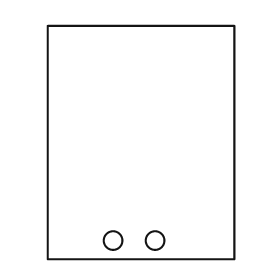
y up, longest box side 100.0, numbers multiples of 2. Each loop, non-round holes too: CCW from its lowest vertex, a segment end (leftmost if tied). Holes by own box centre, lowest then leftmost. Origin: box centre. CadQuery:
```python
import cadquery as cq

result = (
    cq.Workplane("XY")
    .moveTo(-40.0, -50.0)
    .lineTo(40.0, -50.0)
    .lineTo(40.0, 50.0)
    .lineTo(-40.0, 50.0)
    .close()
    .moveTo(-12.0, -42.0)
    .circle(4.0)
    .moveTo(6.0, -42.0)
    .circle(4.0)
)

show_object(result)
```